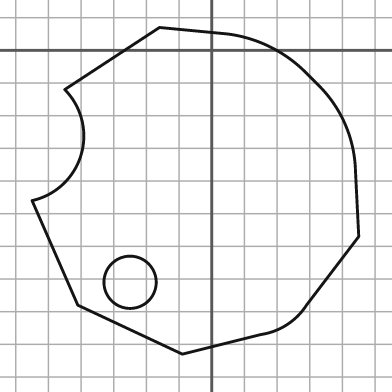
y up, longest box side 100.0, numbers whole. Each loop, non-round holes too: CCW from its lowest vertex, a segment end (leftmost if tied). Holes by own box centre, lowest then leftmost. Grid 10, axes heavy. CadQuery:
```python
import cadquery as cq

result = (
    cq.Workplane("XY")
    .moveTo(-9.0, -93.0)
    .lineTo(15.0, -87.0)
    .threePointArc((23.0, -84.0), (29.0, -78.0))
    .lineTo(45.0, -57.0)
    .lineTo(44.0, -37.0)
    .threePointArc((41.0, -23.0), (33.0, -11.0))
    .lineTo(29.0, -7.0)
    .threePointArc((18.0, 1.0), (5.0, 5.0))
    .lineTo(-16.0, 7.0)
    .lineTo(-45.0, -12.0)
    .threePointArc((-40.0, -32.0), (-55.0, -46.0))
    .lineTo(-41.0, -78.0)
    .close()
    .moveTo(-25.0, -71.0)
    .circle(8.0)
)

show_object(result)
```